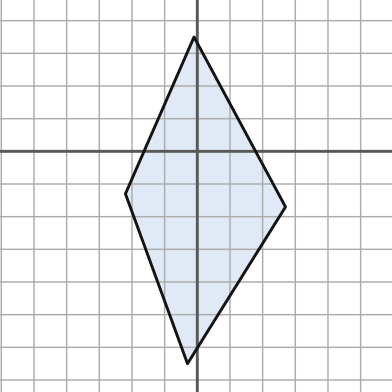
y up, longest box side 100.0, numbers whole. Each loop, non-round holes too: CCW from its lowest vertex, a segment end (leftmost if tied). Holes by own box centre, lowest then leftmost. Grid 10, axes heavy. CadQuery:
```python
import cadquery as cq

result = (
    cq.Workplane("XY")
    .moveTo(-3.0, -65.0)
    .lineTo(27.0, -17.0)
    .lineTo(-1.0, 35.0)
    .lineTo(-22.0, -13.0)
    .close()
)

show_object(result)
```